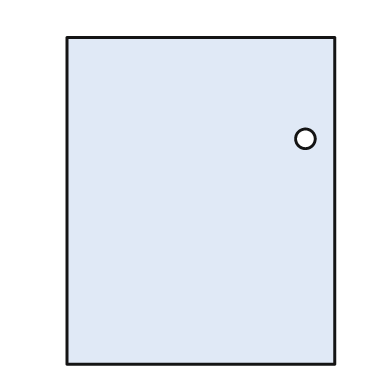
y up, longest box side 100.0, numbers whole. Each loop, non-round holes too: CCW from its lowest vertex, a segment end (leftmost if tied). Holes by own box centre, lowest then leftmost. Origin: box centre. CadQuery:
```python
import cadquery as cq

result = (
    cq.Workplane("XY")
    .moveTo(-41.0, -50.0)
    .lineTo(41.0, -50.0)
    .lineTo(41.0, 50.0)
    .lineTo(-41.0, 50.0)
    .close()
    .moveTo(32.0, 19.0)
    .circle(3.0)
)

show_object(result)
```